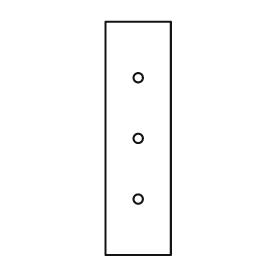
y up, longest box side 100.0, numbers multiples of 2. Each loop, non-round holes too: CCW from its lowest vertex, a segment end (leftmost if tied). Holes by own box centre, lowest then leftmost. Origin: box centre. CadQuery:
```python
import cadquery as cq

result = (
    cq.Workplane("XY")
    .moveTo(-14.0, -50.0)
    .lineTo(14.0, -50.0)
    .lineTo(14.0, 50.0)
    .lineTo(-14.0, 50.0)
    .close()
    .moveTo(0.0, -26.0)
    .circle(2.0)
    .moveTo(0.0, 0.0)
    .circle(2.0)
    .moveTo(0.0, 26.0)
    .circle(2.0)
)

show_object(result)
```